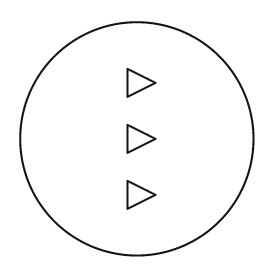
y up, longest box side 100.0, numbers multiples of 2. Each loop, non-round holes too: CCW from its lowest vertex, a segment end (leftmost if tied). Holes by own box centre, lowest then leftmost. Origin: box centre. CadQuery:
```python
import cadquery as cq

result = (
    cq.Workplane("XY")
    .moveTo(0.0, 0.0)
    .circle(50.0)
    .moveTo(-4.0, -30.0)
    .lineTo(8.0, -24.0)
    .lineTo(-4.0, -18.0)
    .close()
    .moveTo(-4.0, -6.0)
    .lineTo(8.0, 0.0)
    .lineTo(-4.0, 6.0)
    .close()
    .moveTo(-4.0, 18.0)
    .lineTo(8.0, 24.0)
    .lineTo(-4.0, 30.0)
    .close()
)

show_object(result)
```